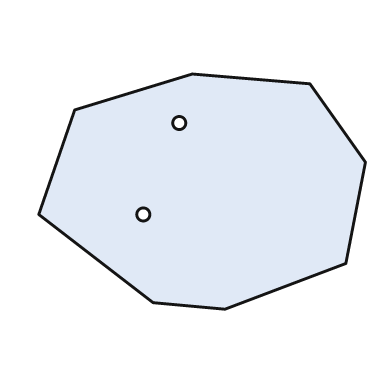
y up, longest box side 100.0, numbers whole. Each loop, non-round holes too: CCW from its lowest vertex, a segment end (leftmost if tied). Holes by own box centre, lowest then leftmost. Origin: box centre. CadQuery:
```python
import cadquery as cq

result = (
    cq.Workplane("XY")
    .moveTo(7.0, -36.0)
    .lineTo(44.0, -22.0)
    .lineTo(50.0, 9.0)
    .lineTo(33.0, 33.0)
    .lineTo(-3.0, 36.0)
    .lineTo(-39.0, 25.0)
    .lineTo(-50.0, -7.0)
    .lineTo(-15.0, -34.0)
    .close()
    .moveTo(-18.0, -7.0)
    .circle(2.0)
    .moveTo(-7.0, 21.0)
    .circle(2.0)
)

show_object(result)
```